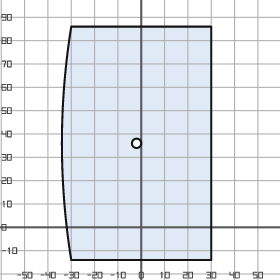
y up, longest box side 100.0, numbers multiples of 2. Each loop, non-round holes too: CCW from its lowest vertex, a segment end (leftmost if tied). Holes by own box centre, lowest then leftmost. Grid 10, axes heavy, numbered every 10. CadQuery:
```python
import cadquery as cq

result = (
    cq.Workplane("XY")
    .moveTo(-30.0, -14.0)
    .lineTo(30.0, -14.0)
    .lineTo(30.0, 86.0)
    .lineTo(-30.0, 86.0)
    .threePointArc((-34.0, 36.0), (-30.0, -14.0))
    .close()
    .moveTo(-2.0, 36.0)
    .circle(2.0)
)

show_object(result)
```